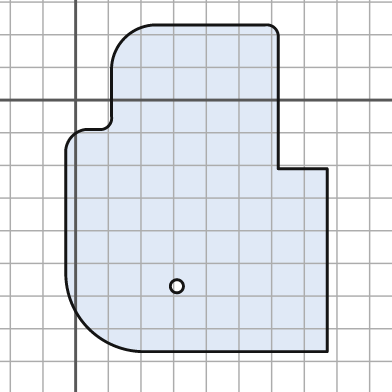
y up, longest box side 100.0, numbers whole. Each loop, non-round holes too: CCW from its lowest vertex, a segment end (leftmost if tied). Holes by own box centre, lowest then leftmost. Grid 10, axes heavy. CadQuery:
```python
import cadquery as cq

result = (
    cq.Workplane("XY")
    .moveTo(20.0, -77.0)
    .lineTo(77.0, -77.0)
    .lineTo(77.0, -21.0)
    .lineTo(62.0, -21.0)
    .lineTo(62.0, 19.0)
    .threePointArc((61.0, 22.0), (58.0, 23.0))
    .lineTo(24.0, 23.0)
    .threePointArc((15.0, 19.0), (11.0, 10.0))
    .lineTo(11.0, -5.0)
    .threePointArc((10.0, -8.0), (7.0, -9.0))
    .lineTo(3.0, -9.0)
    .threePointArc((-1.0, -11.0), (-3.0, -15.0))
    .lineTo(-3.0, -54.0)
    .threePointArc((4.0, -70.0), (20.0, -77.0))
    .close()
    .moveTo(31.0, -57.0)
    .circle(2.0)
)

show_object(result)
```